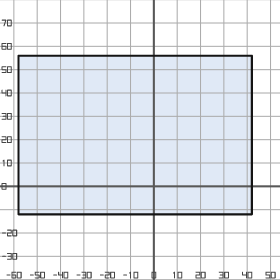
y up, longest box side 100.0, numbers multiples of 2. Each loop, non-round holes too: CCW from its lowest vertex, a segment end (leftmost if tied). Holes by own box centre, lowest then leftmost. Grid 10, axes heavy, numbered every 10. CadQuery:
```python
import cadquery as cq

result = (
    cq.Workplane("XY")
    .moveTo(-58.0, -12.0)
    .lineTo(42.0, -12.0)
    .lineTo(42.0, 56.0)
    .lineTo(-58.0, 56.0)
    .close()
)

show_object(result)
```